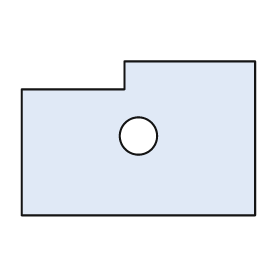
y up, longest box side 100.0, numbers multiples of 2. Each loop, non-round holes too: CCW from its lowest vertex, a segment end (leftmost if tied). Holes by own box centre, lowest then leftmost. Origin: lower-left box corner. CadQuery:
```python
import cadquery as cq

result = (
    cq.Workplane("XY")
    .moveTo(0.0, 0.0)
    .lineTo(100.0, 0.0)
    .lineTo(100.0, 66.0)
    .lineTo(44.0, 66.0)
    .lineTo(44.0, 54.0)
    .lineTo(0.0, 54.0)
    .close()
    .moveTo(50.0, 34.0)
    .circle(8.0)
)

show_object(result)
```